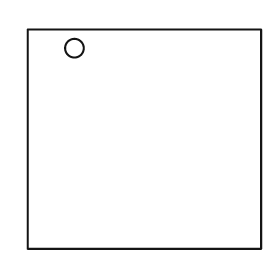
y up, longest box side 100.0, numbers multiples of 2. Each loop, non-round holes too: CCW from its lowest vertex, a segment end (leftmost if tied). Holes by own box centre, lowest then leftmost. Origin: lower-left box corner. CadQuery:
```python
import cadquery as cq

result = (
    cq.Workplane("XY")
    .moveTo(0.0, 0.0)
    .lineTo(100.0, 0.0)
    .lineTo(100.0, 94.0)
    .lineTo(0.0, 94.0)
    .close()
    .moveTo(20.0, 86.0)
    .circle(4.0)
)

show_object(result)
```